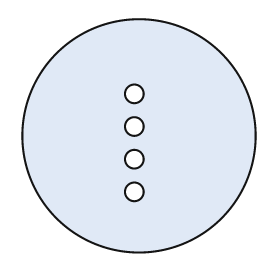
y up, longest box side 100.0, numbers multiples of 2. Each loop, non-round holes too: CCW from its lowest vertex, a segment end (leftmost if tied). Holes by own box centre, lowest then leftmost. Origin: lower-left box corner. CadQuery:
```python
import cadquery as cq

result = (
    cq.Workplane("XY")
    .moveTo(50.0, 50.0)
    .circle(50.0)
    .moveTo(48.0, 26.0)
    .circle(4.0)
    .moveTo(48.0, 40.0)
    .circle(4.0)
    .moveTo(48.0, 54.0)
    .circle(4.0)
    .moveTo(48.0, 68.0)
    .circle(4.0)
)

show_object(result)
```